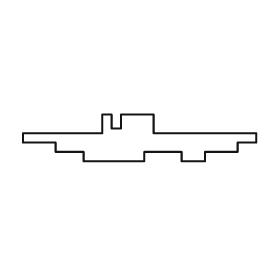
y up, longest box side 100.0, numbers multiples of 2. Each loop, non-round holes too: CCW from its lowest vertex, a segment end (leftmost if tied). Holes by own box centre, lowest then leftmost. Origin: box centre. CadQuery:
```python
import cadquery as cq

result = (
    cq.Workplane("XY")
    .moveTo(-24.0, -10.0)
    .lineTo(2.0, -10.0)
    .lineTo(2.0, -6.0)
    .lineTo(18.0, -6.0)
    .lineTo(18.0, -10.0)
    .lineTo(28.0, -10.0)
    .lineTo(28.0, -6.0)
    .lineTo(42.0, -6.0)
    .lineTo(42.0, -2.0)
    .lineTo(50.0, -2.0)
    .lineTo(50.0, 2.0)
    .lineTo(6.0, 2.0)
    .lineTo(6.0, 10.0)
    .lineTo(-8.0, 10.0)
    .lineTo(-8.0, 4.0)
    .lineTo(-12.0, 4.0)
    .lineTo(-12.0, 10.0)
    .lineTo(-16.0, 10.0)
    .lineTo(-16.0, 2.0)
    .lineTo(-50.0, 2.0)
    .lineTo(-50.0, -2.0)
    .lineTo(-36.0, -2.0)
    .lineTo(-36.0, -6.0)
    .lineTo(-24.0, -6.0)
    .close()
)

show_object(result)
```